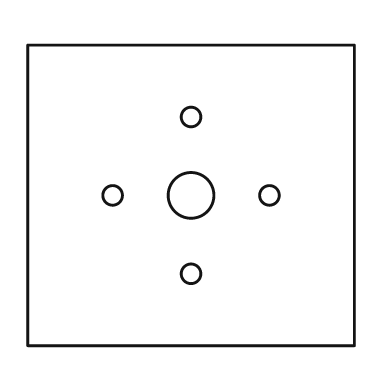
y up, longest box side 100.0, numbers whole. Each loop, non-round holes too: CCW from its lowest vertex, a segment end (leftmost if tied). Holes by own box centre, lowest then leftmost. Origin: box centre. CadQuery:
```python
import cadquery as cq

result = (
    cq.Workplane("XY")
    .moveTo(-50.0, -46.0)
    .lineTo(50.0, -46.0)
    .lineTo(50.0, 46.0)
    .lineTo(-50.0, 46.0)
    .close()
    .moveTo(0.0, -24.0)
    .circle(3.0)
    .moveTo(-24.0, 0.0)
    .circle(3.0)
    .moveTo(0.0, 0.0)
    .circle(7.0)
    .moveTo(24.0, 0.0)
    .circle(3.0)
    .moveTo(0.0, 24.0)
    .circle(3.0)
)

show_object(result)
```